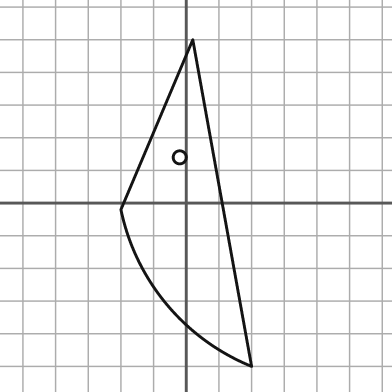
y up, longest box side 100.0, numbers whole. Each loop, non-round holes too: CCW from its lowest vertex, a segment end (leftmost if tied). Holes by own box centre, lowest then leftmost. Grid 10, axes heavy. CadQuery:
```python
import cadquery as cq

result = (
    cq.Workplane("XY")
    .moveTo(20.0, -50.0)
    .lineTo(2.0, 50.0)
    .lineTo(-20.0, -2.0)
    .threePointArc((-6.0, -31.0), (20.0, -50.0))
    .close()
    .moveTo(-2.0, 14.0)
    .circle(2.0)
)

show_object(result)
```